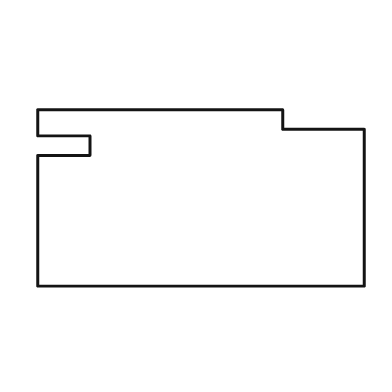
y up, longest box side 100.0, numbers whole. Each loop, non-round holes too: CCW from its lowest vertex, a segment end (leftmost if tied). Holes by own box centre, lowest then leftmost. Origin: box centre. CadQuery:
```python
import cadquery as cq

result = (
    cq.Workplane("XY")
    .moveTo(-50.0, -27.0)
    .lineTo(50.0, -27.0)
    .lineTo(50.0, 21.0)
    .lineTo(25.0, 21.0)
    .lineTo(25.0, 27.0)
    .lineTo(-50.0, 27.0)
    .lineTo(-50.0, 19.0)
    .lineTo(-34.0, 19.0)
    .lineTo(-34.0, 13.0)
    .lineTo(-50.0, 13.0)
    .close()
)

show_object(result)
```